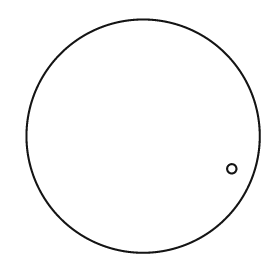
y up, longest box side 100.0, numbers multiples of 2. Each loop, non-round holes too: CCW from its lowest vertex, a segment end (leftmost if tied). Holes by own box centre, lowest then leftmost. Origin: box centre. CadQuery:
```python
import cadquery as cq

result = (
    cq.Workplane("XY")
    .moveTo(0.0, 0.0)
    .circle(50.0)
    .moveTo(38.0, -14.0)
    .circle(2.0)
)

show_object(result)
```